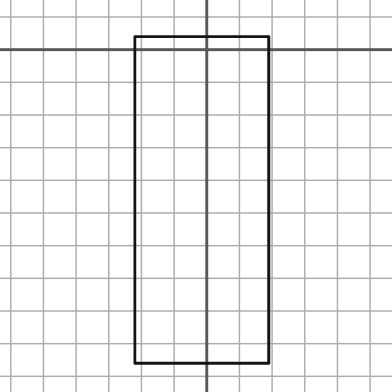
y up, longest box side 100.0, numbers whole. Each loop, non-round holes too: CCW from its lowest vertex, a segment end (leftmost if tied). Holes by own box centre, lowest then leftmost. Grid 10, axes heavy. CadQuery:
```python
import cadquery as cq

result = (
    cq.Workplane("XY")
    .moveTo(-22.0, -96.0)
    .lineTo(19.0, -96.0)
    .lineTo(19.0, 4.0)
    .lineTo(-22.0, 4.0)
    .close()
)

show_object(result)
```